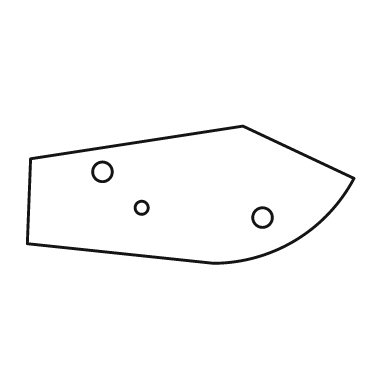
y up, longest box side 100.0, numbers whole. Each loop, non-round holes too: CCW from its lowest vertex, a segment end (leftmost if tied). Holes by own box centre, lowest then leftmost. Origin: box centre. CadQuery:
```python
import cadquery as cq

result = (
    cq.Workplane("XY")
    .moveTo(7.0, -21.0)
    .threePointArc((32.0, -14.0), (50.0, 5.0))
    .lineTo(16.0, 21.0)
    .lineTo(-49.0, 11.0)
    .lineTo(-50.0, -15.0)
    .close()
    .moveTo(22.0, -7.0)
    .circle(3.0)
    .moveTo(-15.0, -4.0)
    .circle(2.0)
    .moveTo(-27.0, 7.0)
    .circle(3.0)
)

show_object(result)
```